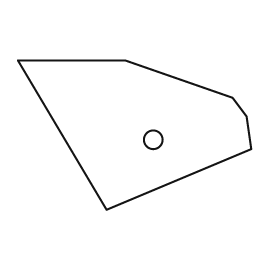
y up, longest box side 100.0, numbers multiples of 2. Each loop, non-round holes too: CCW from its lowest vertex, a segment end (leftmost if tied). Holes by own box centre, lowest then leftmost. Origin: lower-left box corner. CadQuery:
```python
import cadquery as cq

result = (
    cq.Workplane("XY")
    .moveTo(38.0, 0.0)
    .lineTo(100.0, 26.0)
    .lineTo(98.0, 40.0)
    .lineTo(92.0, 48.0)
    .lineTo(46.0, 64.0)
    .lineTo(0.0, 64.0)
    .close()
    .moveTo(58.0, 30.0)
    .circle(4.0)
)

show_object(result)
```